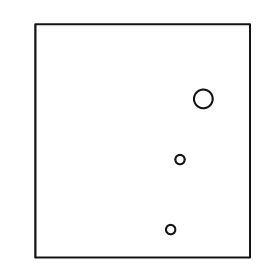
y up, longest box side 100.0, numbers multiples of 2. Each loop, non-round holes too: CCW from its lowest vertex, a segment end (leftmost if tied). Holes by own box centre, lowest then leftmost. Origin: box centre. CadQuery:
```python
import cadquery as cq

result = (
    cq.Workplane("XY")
    .moveTo(-46.0, -50.0)
    .lineTo(46.0, -50.0)
    .lineTo(46.0, 50.0)
    .lineTo(-46.0, 50.0)
    .close()
    .moveTo(12.0, -38.0)
    .circle(2.0)
    .moveTo(16.0, -8.0)
    .circle(2.0)
    .moveTo(26.0, 18.0)
    .circle(4.0)
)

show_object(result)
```